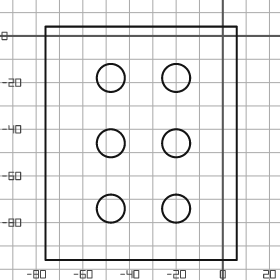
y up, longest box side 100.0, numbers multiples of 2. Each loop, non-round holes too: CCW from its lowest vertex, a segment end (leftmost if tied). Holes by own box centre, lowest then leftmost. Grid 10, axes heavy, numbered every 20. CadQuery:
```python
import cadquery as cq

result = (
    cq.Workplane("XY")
    .moveTo(-76.0, -96.0)
    .lineTo(6.0, -96.0)
    .lineTo(6.0, 4.0)
    .lineTo(-76.0, 4.0)
    .close()
    .moveTo(-48.0, -74.0)
    .circle(6.0)
    .moveTo(-20.0, -74.0)
    .circle(6.0)
    .moveTo(-48.0, -46.0)
    .circle(6.0)
    .moveTo(-20.0, -46.0)
    .circle(6.0)
    .moveTo(-48.0, -18.0)
    .circle(6.0)
    .moveTo(-20.0, -18.0)
    .circle(6.0)
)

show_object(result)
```